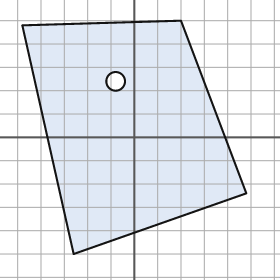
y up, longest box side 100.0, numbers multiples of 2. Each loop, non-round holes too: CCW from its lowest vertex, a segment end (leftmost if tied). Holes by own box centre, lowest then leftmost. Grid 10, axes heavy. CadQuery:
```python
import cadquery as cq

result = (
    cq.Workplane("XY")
    .moveTo(-26.0, -50.0)
    .lineTo(48.0, -24.0)
    .lineTo(20.0, 50.0)
    .lineTo(-48.0, 48.0)
    .close()
    .moveTo(-8.0, 24.0)
    .circle(4.0)
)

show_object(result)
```